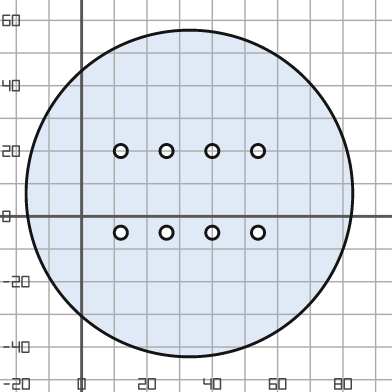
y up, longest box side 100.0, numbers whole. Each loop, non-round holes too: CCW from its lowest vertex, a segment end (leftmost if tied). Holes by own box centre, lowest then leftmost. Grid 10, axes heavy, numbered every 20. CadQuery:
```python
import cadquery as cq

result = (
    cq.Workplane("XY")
    .moveTo(33.0, 7.0)
    .circle(50.0)
    .moveTo(12.0, -5.0)
    .circle(2.0)
    .moveTo(26.0, -5.0)
    .circle(2.0)
    .moveTo(40.0, -5.0)
    .circle(2.0)
    .moveTo(54.0, -5.0)
    .circle(2.0)
    .moveTo(12.0, 20.0)
    .circle(2.0)
    .moveTo(26.0, 20.0)
    .circle(2.0)
    .moveTo(40.0, 20.0)
    .circle(2.0)
    .moveTo(54.0, 20.0)
    .circle(2.0)
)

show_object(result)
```